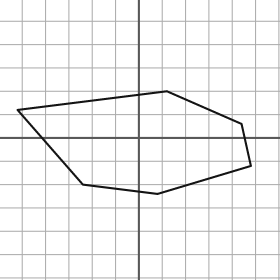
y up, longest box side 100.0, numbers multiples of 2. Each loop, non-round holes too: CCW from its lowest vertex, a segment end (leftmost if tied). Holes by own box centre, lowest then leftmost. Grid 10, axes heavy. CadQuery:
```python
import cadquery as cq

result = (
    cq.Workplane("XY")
    .moveTo(8.0, -24.0)
    .lineTo(48.0, -12.0)
    .lineTo(44.0, 6.0)
    .lineTo(12.0, 20.0)
    .lineTo(-52.0, 12.0)
    .lineTo(-24.0, -20.0)
    .close()
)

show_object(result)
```